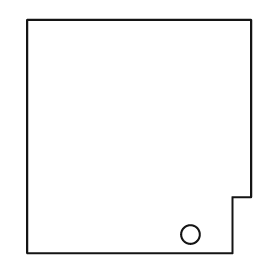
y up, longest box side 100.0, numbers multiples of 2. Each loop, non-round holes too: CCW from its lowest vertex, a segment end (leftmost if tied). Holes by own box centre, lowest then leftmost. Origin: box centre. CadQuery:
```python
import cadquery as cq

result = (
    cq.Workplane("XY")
    .moveTo(-48.0, -50.0)
    .lineTo(40.0, -50.0)
    .lineTo(40.0, -26.0)
    .lineTo(48.0, -26.0)
    .lineTo(48.0, 50.0)
    .lineTo(-48.0, 50.0)
    .close()
    .moveTo(22.0, -42.0)
    .circle(4.0)
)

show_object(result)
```